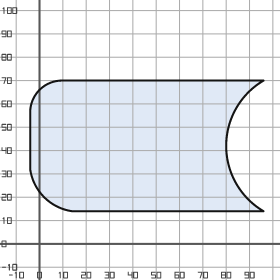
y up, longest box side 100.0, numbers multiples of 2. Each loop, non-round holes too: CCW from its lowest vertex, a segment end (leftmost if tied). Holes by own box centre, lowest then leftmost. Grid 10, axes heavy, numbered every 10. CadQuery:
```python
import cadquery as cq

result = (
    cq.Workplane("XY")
    .moveTo(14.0, 14.0)
    .lineTo(96.0, 14.0)
    .threePointArc((80.0, 42.0), (96.0, 70.0))
    .lineTo(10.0, 70.0)
    .threePointArc((0.0, 66.0), (-4.0, 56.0))
    .lineTo(-4.0, 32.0)
    .threePointArc((2.0, 20.0), (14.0, 14.0))
    .close()
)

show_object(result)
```